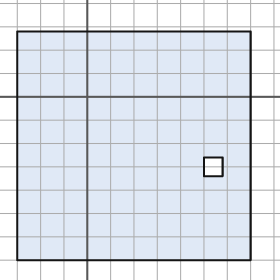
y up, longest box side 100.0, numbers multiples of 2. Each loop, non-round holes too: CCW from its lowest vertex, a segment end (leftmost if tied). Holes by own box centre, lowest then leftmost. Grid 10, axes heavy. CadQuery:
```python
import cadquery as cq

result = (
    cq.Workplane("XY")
    .moveTo(-30.0, -70.0)
    .lineTo(70.0, -70.0)
    .lineTo(70.0, 28.0)
    .lineTo(-30.0, 28.0)
    .close()
    .moveTo(50.0, -34.0)
    .lineTo(58.0, -34.0)
    .lineTo(58.0, -26.0)
    .lineTo(50.0, -26.0)
    .close()
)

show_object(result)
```